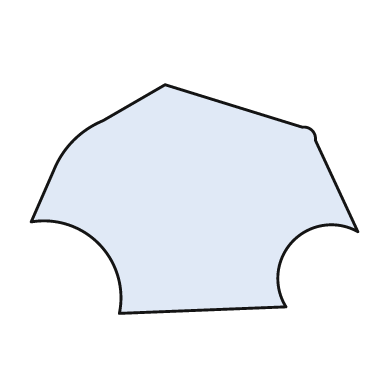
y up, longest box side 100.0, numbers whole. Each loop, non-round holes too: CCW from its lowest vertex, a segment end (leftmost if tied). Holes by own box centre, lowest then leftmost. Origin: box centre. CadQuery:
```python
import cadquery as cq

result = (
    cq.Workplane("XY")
    .moveTo(-23.0, -35.0)
    .lineTo(28.0, -33.0)
    .threePointArc((30.0, -13.0), (50.0, -10.0))
    .lineTo(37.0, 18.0)
    .threePointArc((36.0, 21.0), (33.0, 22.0))
    .lineTo(-9.0, 35.0)
    .lineTo(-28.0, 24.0)
    .threePointArc((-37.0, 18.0), (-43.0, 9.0))
    .lineTo(-50.0, -7.0)
    .threePointArc((-29.0, -14.0), (-23.0, -35.0))
    .close()
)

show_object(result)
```